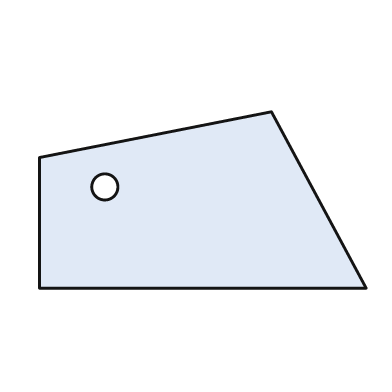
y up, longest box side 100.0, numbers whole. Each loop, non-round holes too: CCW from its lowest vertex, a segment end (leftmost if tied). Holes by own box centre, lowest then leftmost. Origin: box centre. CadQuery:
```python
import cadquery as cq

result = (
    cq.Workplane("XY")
    .moveTo(-50.0, -27.0)
    .lineTo(50.0, -27.0)
    .lineTo(21.0, 27.0)
    .lineTo(-50.0, 13.0)
    .close()
    .moveTo(-30.0, 4.0)
    .circle(4.0)
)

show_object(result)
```